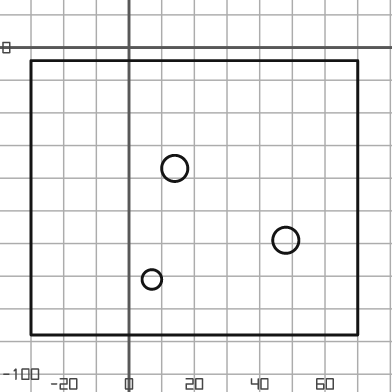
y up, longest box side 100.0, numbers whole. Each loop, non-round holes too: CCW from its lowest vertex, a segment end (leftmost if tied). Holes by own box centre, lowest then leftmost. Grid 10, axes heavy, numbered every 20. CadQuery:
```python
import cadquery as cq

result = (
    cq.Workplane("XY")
    .moveTo(-30.0, -88.0)
    .lineTo(70.0, -88.0)
    .lineTo(70.0, -4.0)
    .lineTo(-30.0, -4.0)
    .close()
    .moveTo(7.0, -71.0)
    .circle(3.0)
    .moveTo(48.0, -59.0)
    .circle(4.0)
    .moveTo(14.0, -37.0)
    .circle(4.0)
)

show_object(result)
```